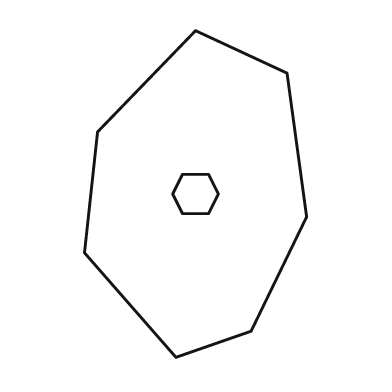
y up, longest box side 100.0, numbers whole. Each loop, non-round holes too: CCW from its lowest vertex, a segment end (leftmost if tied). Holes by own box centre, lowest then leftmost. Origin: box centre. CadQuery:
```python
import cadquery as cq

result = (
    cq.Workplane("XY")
    .moveTo(-6.0, -50.0)
    .lineTo(17.0, -42.0)
    .lineTo(34.0, -7.0)
    .lineTo(28.0, 37.0)
    .lineTo(0.0, 50.0)
    .lineTo(-30.0, 19.0)
    .lineTo(-34.0, -18.0)
    .close()
    .moveTo(-4.0, -6.0)
    .lineTo(4.0, -6.0)
    .lineTo(7.0, 0.0)
    .lineTo(4.0, 6.0)
    .lineTo(-4.0, 6.0)
    .lineTo(-7.0, 0.0)
    .close()
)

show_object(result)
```